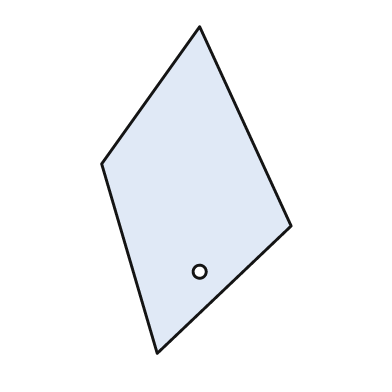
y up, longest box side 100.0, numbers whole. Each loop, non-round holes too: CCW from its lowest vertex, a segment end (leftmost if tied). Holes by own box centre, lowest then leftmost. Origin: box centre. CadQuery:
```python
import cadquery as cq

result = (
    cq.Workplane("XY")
    .moveTo(-12.0, -50.0)
    .lineTo(29.0, -11.0)
    .lineTo(1.0, 50.0)
    .lineTo(-29.0, 8.0)
    .close()
    .moveTo(1.0, -25.0)
    .circle(2.0)
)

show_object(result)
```